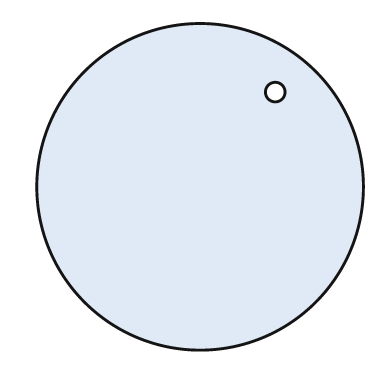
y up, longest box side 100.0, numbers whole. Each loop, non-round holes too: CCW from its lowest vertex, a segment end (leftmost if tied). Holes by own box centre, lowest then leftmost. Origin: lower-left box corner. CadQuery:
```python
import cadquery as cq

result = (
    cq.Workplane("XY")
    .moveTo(50.0, 50.0)
    .circle(50.0)
    .moveTo(73.0, 79.0)
    .circle(3.0)
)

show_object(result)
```